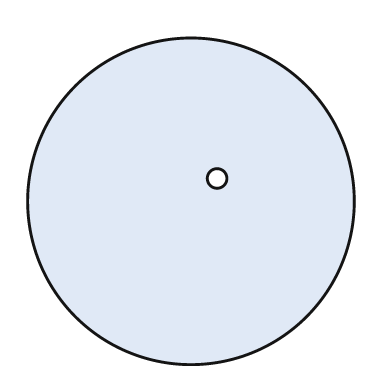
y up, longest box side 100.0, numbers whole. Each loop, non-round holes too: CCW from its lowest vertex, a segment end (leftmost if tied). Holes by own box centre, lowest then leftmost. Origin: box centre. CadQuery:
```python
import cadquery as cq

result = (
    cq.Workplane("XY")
    .moveTo(0.0, 0.0)
    .circle(50.0)
    .moveTo(8.0, 7.0)
    .circle(3.0)
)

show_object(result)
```